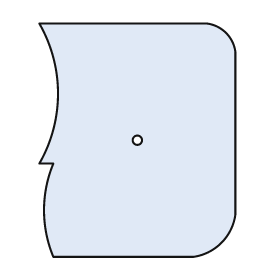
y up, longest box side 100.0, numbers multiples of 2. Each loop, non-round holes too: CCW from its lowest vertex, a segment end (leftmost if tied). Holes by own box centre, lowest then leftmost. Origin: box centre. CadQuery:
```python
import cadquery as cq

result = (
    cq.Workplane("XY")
    .moveTo(-36.0, -50.0)
    .lineTo(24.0, -50.0)
    .threePointArc((36.0, -44.0), (42.0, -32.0))
    .lineTo(42.0, 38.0)
    .threePointArc((38.0, 46.0), (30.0, 50.0))
    .lineTo(-42.0, 50.0)
    .threePointArc((-34.0, 20.0), (-42.0, -10.0))
    .lineTo(-36.0, -10.0)
    .threePointArc((-40.0, -30.0), (-36.0, -50.0))
    .close()
    .moveTo(0.0, 0.0)
    .circle(2.0)
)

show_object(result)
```